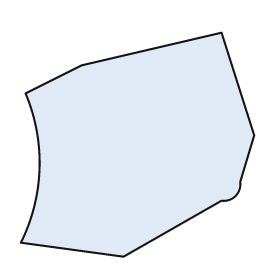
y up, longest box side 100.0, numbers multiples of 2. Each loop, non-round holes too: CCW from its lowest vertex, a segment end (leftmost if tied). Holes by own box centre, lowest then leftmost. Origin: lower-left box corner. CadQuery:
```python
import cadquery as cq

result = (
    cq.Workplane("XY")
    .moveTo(44.0, 0.0)
    .lineTo(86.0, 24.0)
    .threePointArc((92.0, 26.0), (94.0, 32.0))
    .lineTo(100.0, 52.0)
    .lineTo(86.0, 96.0)
    .lineTo(26.0, 82.0)
    .lineTo(2.0, 70.0)
    .threePointArc((8.0, 38.0), (0.0, 6.0))
    .close()
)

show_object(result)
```